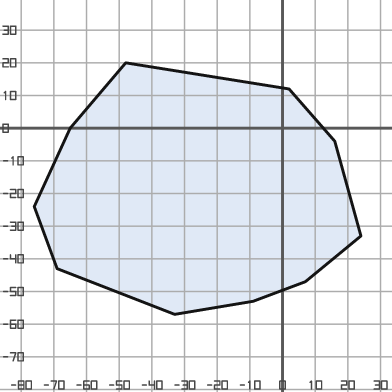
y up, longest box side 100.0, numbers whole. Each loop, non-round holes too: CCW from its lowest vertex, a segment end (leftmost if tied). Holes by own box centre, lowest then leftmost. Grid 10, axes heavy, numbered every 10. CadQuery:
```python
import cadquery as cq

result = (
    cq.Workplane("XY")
    .moveTo(-33.0, -57.0)
    .lineTo(-9.0, -53.0)
    .lineTo(7.0, -47.0)
    .lineTo(24.0, -33.0)
    .lineTo(16.0, -4.0)
    .lineTo(2.0, 12.0)
    .lineTo(-48.0, 20.0)
    .lineTo(-65.0, 0.0)
    .lineTo(-76.0, -24.0)
    .lineTo(-69.0, -43.0)
    .close()
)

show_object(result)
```